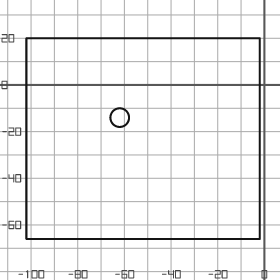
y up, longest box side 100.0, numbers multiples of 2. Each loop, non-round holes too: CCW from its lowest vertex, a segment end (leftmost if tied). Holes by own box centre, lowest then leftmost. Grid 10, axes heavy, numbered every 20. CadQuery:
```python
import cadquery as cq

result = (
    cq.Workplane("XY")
    .moveTo(-102.0, -66.0)
    .lineTo(-2.0, -66.0)
    .lineTo(-2.0, 20.0)
    .lineTo(-102.0, 20.0)
    .close()
    .moveTo(-62.0, -14.0)
    .circle(4.0)
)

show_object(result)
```